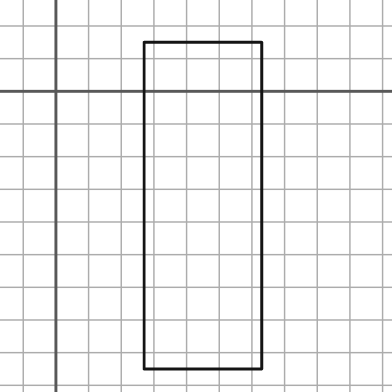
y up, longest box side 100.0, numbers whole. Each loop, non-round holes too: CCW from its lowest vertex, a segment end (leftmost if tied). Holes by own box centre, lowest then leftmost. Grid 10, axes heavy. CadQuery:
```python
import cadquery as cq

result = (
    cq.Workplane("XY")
    .moveTo(27.0, -85.0)
    .lineTo(63.0, -85.0)
    .lineTo(63.0, 15.0)
    .lineTo(27.0, 15.0)
    .close()
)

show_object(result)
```